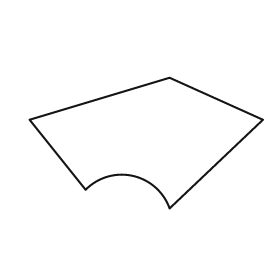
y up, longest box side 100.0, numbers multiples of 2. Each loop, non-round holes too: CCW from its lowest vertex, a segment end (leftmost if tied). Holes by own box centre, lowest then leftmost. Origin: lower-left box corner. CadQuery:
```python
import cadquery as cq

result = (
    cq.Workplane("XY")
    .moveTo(60.0, 0.0)
    .lineTo(100.0, 38.0)
    .lineTo(60.0, 56.0)
    .lineTo(0.0, 38.0)
    .lineTo(24.0, 8.0)
    .threePointArc((44.0, 14.0), (60.0, 0.0))
    .close()
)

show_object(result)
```